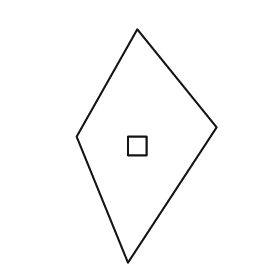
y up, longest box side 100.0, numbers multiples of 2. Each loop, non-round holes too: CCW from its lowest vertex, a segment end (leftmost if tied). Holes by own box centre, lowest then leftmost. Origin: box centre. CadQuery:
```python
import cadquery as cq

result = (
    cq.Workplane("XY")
    .moveTo(-8.0, -50.0)
    .lineTo(30.0, 8.0)
    .lineTo(-4.0, 50.0)
    .lineTo(-30.0, 4.0)
    .close()
    .moveTo(-8.0, -4.0)
    .lineTo(0.0, -4.0)
    .lineTo(0.0, 4.0)
    .lineTo(-8.0, 4.0)
    .close()
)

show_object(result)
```